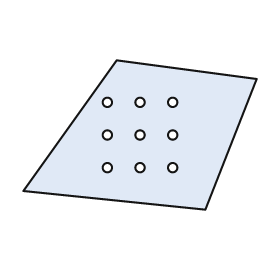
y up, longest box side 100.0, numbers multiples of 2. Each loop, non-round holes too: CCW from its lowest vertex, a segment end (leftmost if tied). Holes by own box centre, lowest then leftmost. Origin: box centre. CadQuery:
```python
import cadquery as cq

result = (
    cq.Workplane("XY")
    .moveTo(28.0, -32.0)
    .lineTo(50.0, 24.0)
    .lineTo(-10.0, 32.0)
    .lineTo(-50.0, -24.0)
    .close()
    .moveTo(-14.0, -14.0)
    .circle(2.0)
    .moveTo(0.0, -14.0)
    .circle(2.0)
    .moveTo(14.0, -14.0)
    .circle(2.0)
    .moveTo(-14.0, 0.0)
    .circle(2.0)
    .moveTo(0.0, 0.0)
    .circle(2.0)
    .moveTo(14.0, 0.0)
    .circle(2.0)
    .moveTo(-14.0, 14.0)
    .circle(2.0)
    .moveTo(0.0, 14.0)
    .circle(2.0)
    .moveTo(14.0, 14.0)
    .circle(2.0)
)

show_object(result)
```